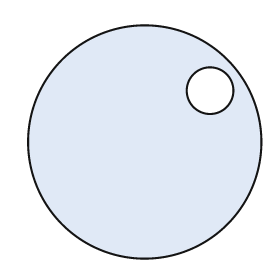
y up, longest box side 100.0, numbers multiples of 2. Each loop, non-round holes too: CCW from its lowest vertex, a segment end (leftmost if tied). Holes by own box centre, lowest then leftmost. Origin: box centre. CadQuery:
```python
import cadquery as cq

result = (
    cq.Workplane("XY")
    .moveTo(0.0, 0.0)
    .circle(50.0)
    .moveTo(28.0, 22.0)
    .circle(10.0)
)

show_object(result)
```